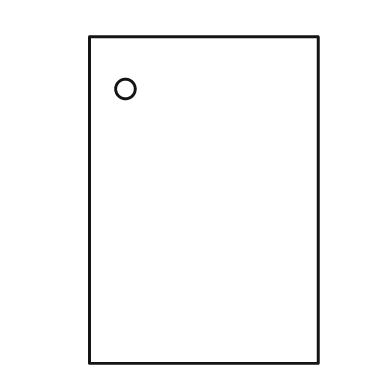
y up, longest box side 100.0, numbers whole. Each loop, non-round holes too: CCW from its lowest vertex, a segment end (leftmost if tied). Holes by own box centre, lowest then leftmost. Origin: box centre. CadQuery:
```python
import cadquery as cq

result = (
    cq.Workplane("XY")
    .moveTo(-35.0, -50.0)
    .lineTo(35.0, -50.0)
    .lineTo(35.0, 50.0)
    .lineTo(-35.0, 50.0)
    .close()
    .moveTo(-24.0, 34.0)
    .circle(3.0)
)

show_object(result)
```